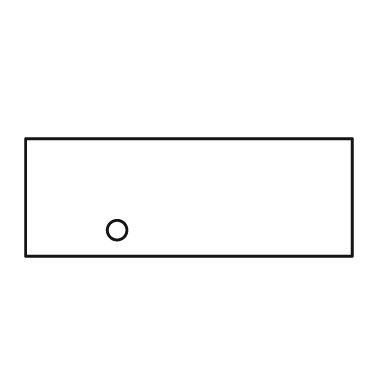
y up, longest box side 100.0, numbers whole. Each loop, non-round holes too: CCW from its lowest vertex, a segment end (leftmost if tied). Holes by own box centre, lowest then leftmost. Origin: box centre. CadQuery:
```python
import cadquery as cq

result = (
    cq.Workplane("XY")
    .moveTo(-50.0, -18.0)
    .lineTo(50.0, -18.0)
    .lineTo(50.0, 18.0)
    .lineTo(-50.0, 18.0)
    .close()
    .moveTo(-22.0, -10.0)
    .circle(3.0)
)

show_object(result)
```